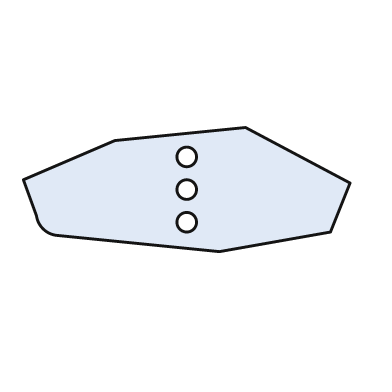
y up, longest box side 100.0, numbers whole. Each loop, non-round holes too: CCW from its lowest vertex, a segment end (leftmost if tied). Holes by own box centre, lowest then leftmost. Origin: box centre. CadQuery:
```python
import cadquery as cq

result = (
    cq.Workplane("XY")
    .moveTo(10.0, -19.0)
    .lineTo(44.0, -13.0)
    .lineTo(50.0, 2.0)
    .lineTo(18.0, 19.0)
    .lineTo(-22.0, 15.0)
    .lineTo(-50.0, 3.0)
    .lineTo(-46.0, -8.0)
    .threePointArc((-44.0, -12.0), (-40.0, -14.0))
    .close()
    .moveTo(0.0, -10.0)
    .circle(3.0)
    .moveTo(0.0, 0.0)
    .circle(3.0)
    .moveTo(0.0, 10.0)
    .circle(3.0)
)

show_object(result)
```